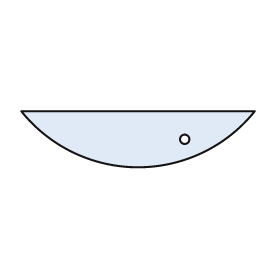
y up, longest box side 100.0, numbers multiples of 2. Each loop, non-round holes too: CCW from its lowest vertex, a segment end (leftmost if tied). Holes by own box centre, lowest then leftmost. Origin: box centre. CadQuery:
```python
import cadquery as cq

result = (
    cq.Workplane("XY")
    .moveTo(-50.0, 12.0)
    .threePointArc((0.0, -12.0), (50.0, 12.0))
    .close()
    .moveTo(20.0, 0.0)
    .circle(2.0)
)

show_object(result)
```